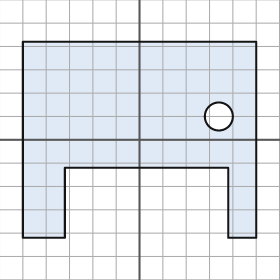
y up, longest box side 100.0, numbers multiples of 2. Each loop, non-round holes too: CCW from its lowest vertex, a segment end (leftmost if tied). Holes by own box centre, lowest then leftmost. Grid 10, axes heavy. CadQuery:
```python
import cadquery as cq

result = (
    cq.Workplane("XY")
    .moveTo(-50.0, -42.0)
    .lineTo(-32.0, -42.0)
    .lineTo(-32.0, -12.0)
    .lineTo(38.0, -12.0)
    .lineTo(38.0, -42.0)
    .lineTo(50.0, -42.0)
    .lineTo(50.0, 42.0)
    .lineTo(-50.0, 42.0)
    .close()
    .moveTo(34.0, 10.0)
    .circle(6.0)
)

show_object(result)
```